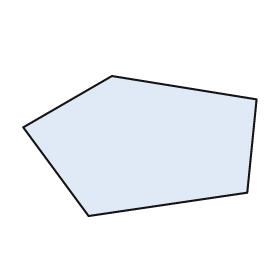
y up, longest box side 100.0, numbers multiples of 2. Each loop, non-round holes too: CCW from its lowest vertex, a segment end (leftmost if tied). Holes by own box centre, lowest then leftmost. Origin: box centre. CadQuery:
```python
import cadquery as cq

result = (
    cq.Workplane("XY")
    .moveTo(-22.0, -30.0)
    .lineTo(46.0, -20.0)
    .lineTo(50.0, 20.0)
    .lineTo(-12.0, 30.0)
    .lineTo(-50.0, 8.0)
    .close()
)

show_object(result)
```